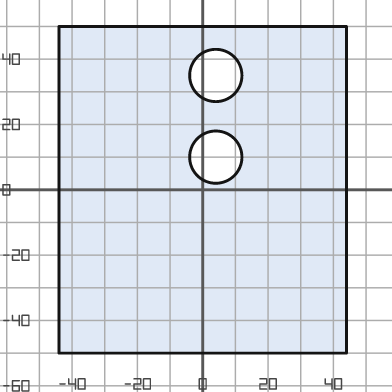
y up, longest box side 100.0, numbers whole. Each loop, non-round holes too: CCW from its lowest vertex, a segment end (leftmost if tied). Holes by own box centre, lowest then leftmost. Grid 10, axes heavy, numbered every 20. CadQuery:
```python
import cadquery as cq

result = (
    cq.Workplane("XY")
    .moveTo(-44.0, -50.0)
    .lineTo(44.0, -50.0)
    .lineTo(44.0, 50.0)
    .lineTo(-44.0, 50.0)
    .close()
    .moveTo(4.0, 10.0)
    .circle(8.0)
    .moveTo(4.0, 35.0)
    .circle(8.0)
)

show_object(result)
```